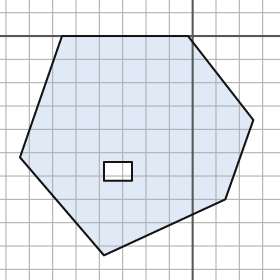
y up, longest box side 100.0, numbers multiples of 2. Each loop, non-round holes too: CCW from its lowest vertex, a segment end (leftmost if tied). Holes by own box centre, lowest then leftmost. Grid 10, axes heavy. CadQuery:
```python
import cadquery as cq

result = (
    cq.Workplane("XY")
    .moveTo(-38.0, -94.0)
    .lineTo(14.0, -70.0)
    .lineTo(26.0, -36.0)
    .lineTo(-2.0, 0.0)
    .lineTo(-56.0, 0.0)
    .lineTo(-74.0, -52.0)
    .close()
    .moveTo(-38.0, -62.0)
    .lineTo(-26.0, -62.0)
    .lineTo(-26.0, -54.0)
    .lineTo(-38.0, -54.0)
    .close()
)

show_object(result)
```